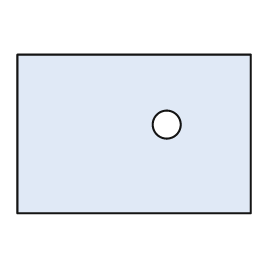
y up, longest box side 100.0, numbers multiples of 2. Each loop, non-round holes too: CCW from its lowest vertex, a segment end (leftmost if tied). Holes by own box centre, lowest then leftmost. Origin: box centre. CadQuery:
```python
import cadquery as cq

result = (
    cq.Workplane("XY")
    .moveTo(-50.0, -34.0)
    .lineTo(50.0, -34.0)
    .lineTo(50.0, 34.0)
    .lineTo(-50.0, 34.0)
    .close()
    .moveTo(14.0, 4.0)
    .circle(6.0)
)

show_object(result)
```